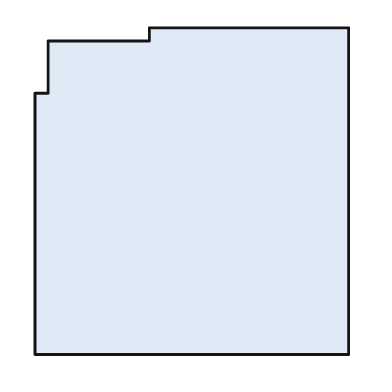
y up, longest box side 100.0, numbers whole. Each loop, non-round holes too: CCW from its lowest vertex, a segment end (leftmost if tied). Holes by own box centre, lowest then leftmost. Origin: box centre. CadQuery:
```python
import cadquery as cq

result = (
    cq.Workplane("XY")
    .moveTo(-48.0, -50.0)
    .lineTo(48.0, -50.0)
    .lineTo(48.0, 50.0)
    .lineTo(-13.0, 50.0)
    .lineTo(-13.0, 46.0)
    .lineTo(-44.0, 46.0)
    .lineTo(-44.0, 30.0)
    .lineTo(-48.0, 30.0)
    .close()
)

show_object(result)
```